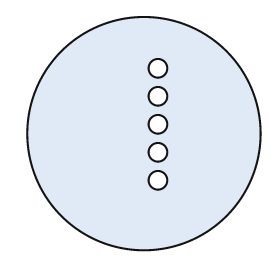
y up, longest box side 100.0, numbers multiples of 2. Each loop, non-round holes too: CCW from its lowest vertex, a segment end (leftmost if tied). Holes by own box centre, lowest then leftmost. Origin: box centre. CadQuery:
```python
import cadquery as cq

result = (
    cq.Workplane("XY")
    .moveTo(0.0, 0.0)
    .circle(50.0)
    .moveTo(6.0, -20.0)
    .circle(4.0)
    .moveTo(6.0, -8.0)
    .circle(4.0)
    .moveTo(6.0, 4.0)
    .circle(4.0)
    .moveTo(6.0, 16.0)
    .circle(4.0)
    .moveTo(6.0, 28.0)
    .circle(4.0)
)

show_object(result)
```